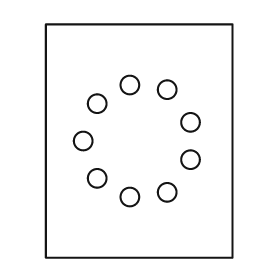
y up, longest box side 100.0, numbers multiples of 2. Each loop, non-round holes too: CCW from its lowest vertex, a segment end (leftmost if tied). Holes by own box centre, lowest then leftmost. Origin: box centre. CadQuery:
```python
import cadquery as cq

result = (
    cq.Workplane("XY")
    .moveTo(-40.0, -50.0)
    .lineTo(40.0, -50.0)
    .lineTo(40.0, 50.0)
    .lineTo(-40.0, 50.0)
    .close()
    .moveTo(-4.0, -24.0)
    .circle(4.0)
    .moveTo(12.0, -22.0)
    .circle(4.0)
    .moveTo(-18.0, -16.0)
    .circle(4.0)
    .moveTo(22.0, -8.0)
    .circle(4.0)
    .moveTo(-24.0, 0.0)
    .circle(4.0)
    .moveTo(22.0, 8.0)
    .circle(4.0)
    .moveTo(-18.0, 16.0)
    .circle(4.0)
    .moveTo(12.0, 22.0)
    .circle(4.0)
    .moveTo(-4.0, 24.0)
    .circle(4.0)
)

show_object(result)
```